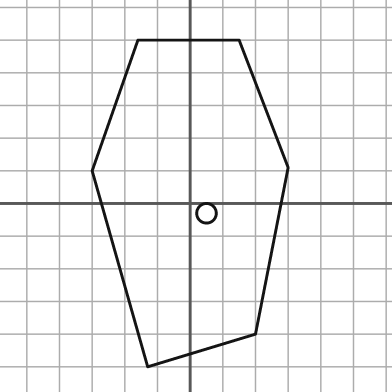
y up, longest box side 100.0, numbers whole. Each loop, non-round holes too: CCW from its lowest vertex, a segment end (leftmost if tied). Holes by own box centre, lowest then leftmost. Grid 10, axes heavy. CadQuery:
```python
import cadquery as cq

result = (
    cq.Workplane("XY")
    .moveTo(-13.0, -50.0)
    .lineTo(20.0, -40.0)
    .lineTo(30.0, 11.0)
    .lineTo(15.0, 50.0)
    .lineTo(-16.0, 50.0)
    .lineTo(-30.0, 10.0)
    .close()
    .moveTo(5.0, -3.0)
    .circle(3.0)
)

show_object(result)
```